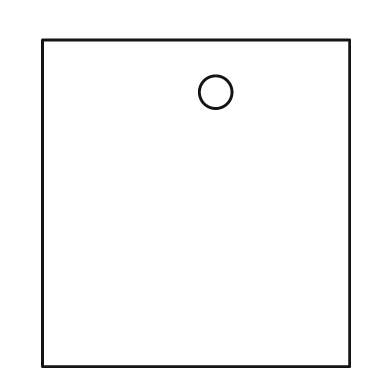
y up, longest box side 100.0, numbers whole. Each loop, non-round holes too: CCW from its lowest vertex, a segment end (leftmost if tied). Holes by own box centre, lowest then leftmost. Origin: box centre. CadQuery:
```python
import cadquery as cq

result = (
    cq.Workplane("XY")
    .moveTo(-47.0, -50.0)
    .lineTo(47.0, -50.0)
    .lineTo(47.0, 50.0)
    .lineTo(-47.0, 50.0)
    .close()
    .moveTo(6.0, 34.0)
    .circle(5.0)
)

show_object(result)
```